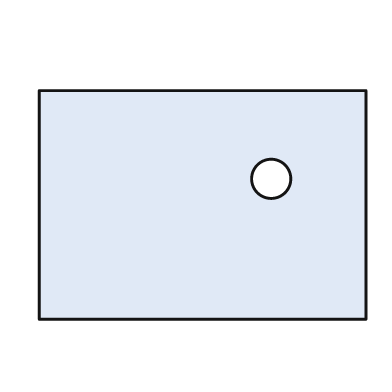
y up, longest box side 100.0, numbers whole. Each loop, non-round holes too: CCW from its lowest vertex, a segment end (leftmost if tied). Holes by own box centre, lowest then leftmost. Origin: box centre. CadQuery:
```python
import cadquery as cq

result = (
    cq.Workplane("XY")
    .moveTo(-50.0, -35.0)
    .lineTo(50.0, -35.0)
    .lineTo(50.0, 35.0)
    .lineTo(-50.0, 35.0)
    .close()
    .moveTo(21.0, 8.0)
    .circle(6.0)
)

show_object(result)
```